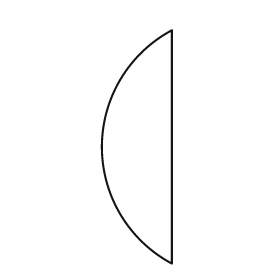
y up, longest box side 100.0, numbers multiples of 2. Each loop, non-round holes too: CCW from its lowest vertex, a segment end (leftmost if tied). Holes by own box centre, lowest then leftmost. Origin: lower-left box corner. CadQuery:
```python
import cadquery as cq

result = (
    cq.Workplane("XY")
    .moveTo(30.0, 0.0)
    .lineTo(30.0, 100.0)
    .threePointArc((0.0, 50.0), (30.0, 0.0))
    .close()
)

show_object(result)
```